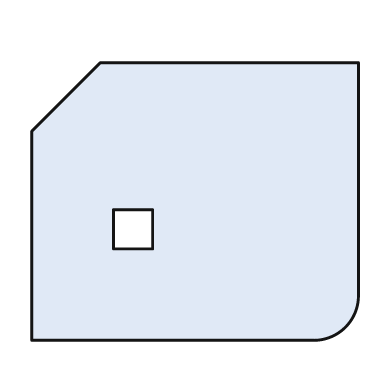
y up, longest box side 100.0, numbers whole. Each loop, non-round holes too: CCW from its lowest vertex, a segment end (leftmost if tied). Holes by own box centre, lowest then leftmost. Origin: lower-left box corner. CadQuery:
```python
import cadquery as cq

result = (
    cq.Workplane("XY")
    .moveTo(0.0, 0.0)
    .lineTo(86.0, 0.0)
    .threePointArc((96.0, 4.0), (100.0, 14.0))
    .lineTo(100.0, 85.0)
    .lineTo(21.0, 85.0)
    .lineTo(0.0, 64.0)
    .close()
    .moveTo(25.0, 28.0)
    .lineTo(37.0, 28.0)
    .lineTo(37.0, 40.0)
    .lineTo(25.0, 40.0)
    .close()
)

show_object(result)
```